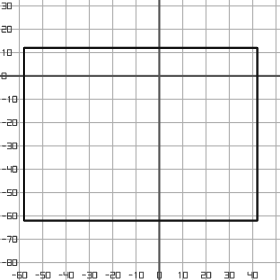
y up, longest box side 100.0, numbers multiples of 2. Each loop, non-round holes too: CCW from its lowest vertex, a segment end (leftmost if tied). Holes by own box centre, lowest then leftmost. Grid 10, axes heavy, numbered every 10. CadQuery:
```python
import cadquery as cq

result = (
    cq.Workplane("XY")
    .moveTo(-58.0, -62.0)
    .lineTo(42.0, -62.0)
    .lineTo(42.0, 12.0)
    .lineTo(-58.0, 12.0)
    .close()
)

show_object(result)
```